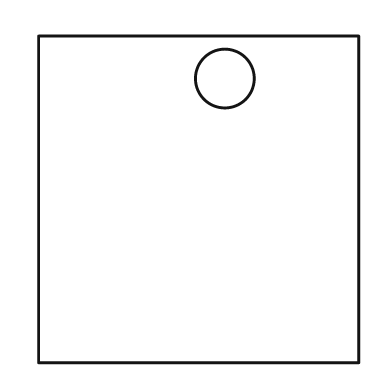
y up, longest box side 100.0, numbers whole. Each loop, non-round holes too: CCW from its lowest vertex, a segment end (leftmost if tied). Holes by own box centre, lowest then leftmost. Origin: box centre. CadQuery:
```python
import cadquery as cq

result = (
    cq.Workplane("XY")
    .moveTo(-49.0, -50.0)
    .lineTo(49.0, -50.0)
    .lineTo(49.0, 50.0)
    .lineTo(-49.0, 50.0)
    .close()
    .moveTo(8.0, 37.0)
    .circle(9.0)
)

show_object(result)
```